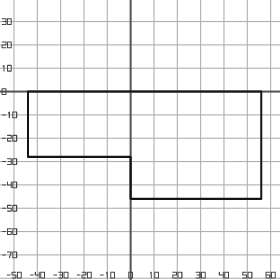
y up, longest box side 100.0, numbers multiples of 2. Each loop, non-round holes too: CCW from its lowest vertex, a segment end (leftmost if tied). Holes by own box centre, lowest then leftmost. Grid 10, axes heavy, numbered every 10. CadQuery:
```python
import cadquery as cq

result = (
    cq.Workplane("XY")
    .moveTo(0.0, -46.0)
    .lineTo(56.0, -46.0)
    .lineTo(56.0, 0.0)
    .lineTo(-44.0, 0.0)
    .lineTo(-44.0, -28.0)
    .lineTo(0.0, -28.0)
    .close()
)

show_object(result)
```